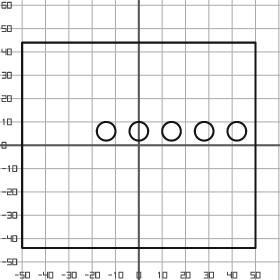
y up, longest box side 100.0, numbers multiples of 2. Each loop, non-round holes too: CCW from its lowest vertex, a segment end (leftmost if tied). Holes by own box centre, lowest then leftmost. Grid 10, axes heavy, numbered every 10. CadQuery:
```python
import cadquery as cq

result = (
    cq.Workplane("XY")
    .moveTo(-50.0, -44.0)
    .lineTo(50.0, -44.0)
    .lineTo(50.0, 44.0)
    .lineTo(-50.0, 44.0)
    .close()
    .moveTo(-14.0, 6.0)
    .circle(4.0)
    .moveTo(0.0, 6.0)
    .circle(4.0)
    .moveTo(14.0, 6.0)
    .circle(4.0)
    .moveTo(28.0, 6.0)
    .circle(4.0)
    .moveTo(42.0, 6.0)
    .circle(4.0)
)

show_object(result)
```